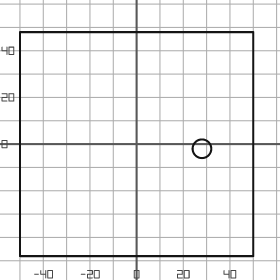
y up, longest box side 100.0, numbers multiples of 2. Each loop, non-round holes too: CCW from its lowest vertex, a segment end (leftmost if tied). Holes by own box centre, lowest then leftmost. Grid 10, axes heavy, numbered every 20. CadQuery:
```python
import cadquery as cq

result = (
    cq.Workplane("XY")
    .moveTo(-50.0, -48.0)
    .lineTo(50.0, -48.0)
    .lineTo(50.0, 48.0)
    .lineTo(-50.0, 48.0)
    .close()
    .moveTo(28.0, -2.0)
    .circle(4.0)
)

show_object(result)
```